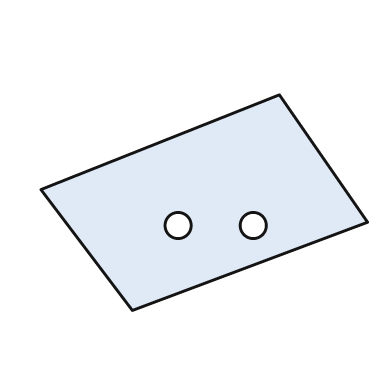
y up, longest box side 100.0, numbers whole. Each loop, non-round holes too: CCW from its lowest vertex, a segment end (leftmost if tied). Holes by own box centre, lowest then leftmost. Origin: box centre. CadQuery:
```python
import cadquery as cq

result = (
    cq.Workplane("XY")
    .moveTo(-22.0, -33.0)
    .lineTo(50.0, -6.0)
    .lineTo(23.0, 33.0)
    .lineTo(-50.0, 4.0)
    .close()
    .moveTo(-8.0, -7.0)
    .circle(4.0)
    .moveTo(15.0, -7.0)
    .circle(4.0)
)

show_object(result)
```